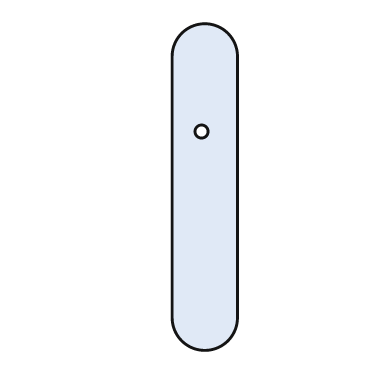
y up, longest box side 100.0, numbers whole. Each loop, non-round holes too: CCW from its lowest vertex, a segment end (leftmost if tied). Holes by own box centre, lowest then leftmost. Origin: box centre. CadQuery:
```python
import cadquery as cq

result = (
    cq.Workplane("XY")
    .moveTo(-10.0, -40.0)
    .threePointArc((0.0, -50.0), (10.0, -40.0))
    .lineTo(10.0, 40.0)
    .threePointArc((0.0, 50.0), (-10.0, 40.0))
    .close()
    .moveTo(-1.0, 17.0)
    .circle(2.0)
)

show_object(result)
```